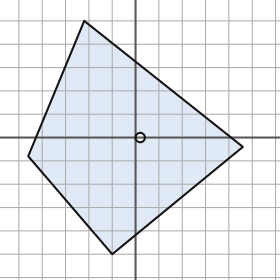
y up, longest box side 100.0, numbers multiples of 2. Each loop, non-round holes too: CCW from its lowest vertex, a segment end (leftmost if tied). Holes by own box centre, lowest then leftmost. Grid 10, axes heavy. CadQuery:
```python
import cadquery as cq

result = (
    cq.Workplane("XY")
    .moveTo(-10.0, -50.0)
    .lineTo(46.0, -4.0)
    .lineTo(-22.0, 50.0)
    .lineTo(-46.0, -8.0)
    .close()
    .moveTo(2.0, 0.0)
    .circle(2.0)
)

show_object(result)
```